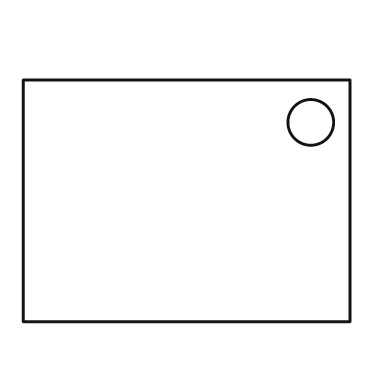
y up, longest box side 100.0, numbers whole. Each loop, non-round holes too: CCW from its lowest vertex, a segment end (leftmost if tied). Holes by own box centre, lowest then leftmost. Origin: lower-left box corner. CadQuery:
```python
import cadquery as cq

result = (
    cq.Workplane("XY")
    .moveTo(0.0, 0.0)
    .lineTo(100.0, 0.0)
    .lineTo(100.0, 74.0)
    .lineTo(0.0, 74.0)
    .close()
    .moveTo(88.0, 61.0)
    .circle(7.0)
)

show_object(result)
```